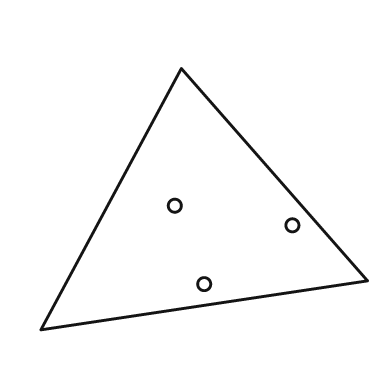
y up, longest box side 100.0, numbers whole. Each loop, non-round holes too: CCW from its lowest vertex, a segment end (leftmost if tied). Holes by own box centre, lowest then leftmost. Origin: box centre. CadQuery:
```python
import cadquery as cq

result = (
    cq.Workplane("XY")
    .moveTo(-50.0, -40.0)
    .lineTo(50.0, -25.0)
    .lineTo(-7.0, 40.0)
    .close()
    .moveTo(0.0, -26.0)
    .circle(2.0)
    .moveTo(27.0, -8.0)
    .circle(2.0)
    .moveTo(-9.0, -2.0)
    .circle(2.0)
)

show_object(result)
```